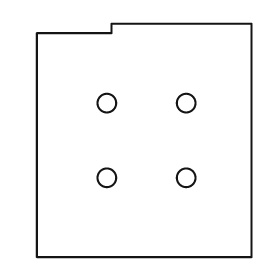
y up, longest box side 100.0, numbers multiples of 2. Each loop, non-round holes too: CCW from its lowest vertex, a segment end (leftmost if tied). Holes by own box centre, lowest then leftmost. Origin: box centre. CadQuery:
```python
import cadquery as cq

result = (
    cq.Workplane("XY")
    .moveTo(-46.0, -50.0)
    .lineTo(46.0, -50.0)
    .lineTo(46.0, 50.0)
    .lineTo(-14.0, 50.0)
    .lineTo(-14.0, 46.0)
    .lineTo(-46.0, 46.0)
    .close()
    .moveTo(-16.0, -16.0)
    .circle(4.0)
    .moveTo(18.0, -16.0)
    .circle(4.0)
    .moveTo(-16.0, 16.0)
    .circle(4.0)
    .moveTo(18.0, 16.0)
    .circle(4.0)
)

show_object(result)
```